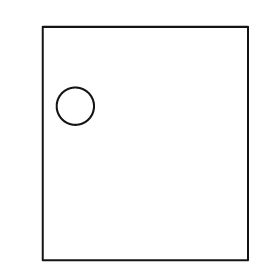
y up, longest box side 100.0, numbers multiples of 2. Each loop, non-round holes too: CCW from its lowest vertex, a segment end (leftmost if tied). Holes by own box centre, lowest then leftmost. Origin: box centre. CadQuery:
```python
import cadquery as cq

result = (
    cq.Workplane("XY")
    .moveTo(-44.0, -50.0)
    .lineTo(44.0, -50.0)
    .lineTo(44.0, 50.0)
    .lineTo(-44.0, 50.0)
    .close()
    .moveTo(-30.0, 16.0)
    .circle(8.0)
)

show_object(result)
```